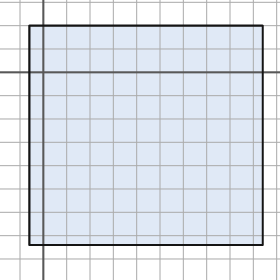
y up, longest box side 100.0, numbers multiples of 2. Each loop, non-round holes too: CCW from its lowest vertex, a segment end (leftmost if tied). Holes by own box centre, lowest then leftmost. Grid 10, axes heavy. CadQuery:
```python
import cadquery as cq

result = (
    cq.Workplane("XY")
    .moveTo(-6.0, -74.0)
    .lineTo(94.0, -74.0)
    .lineTo(94.0, 20.0)
    .lineTo(-6.0, 20.0)
    .close()
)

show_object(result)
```